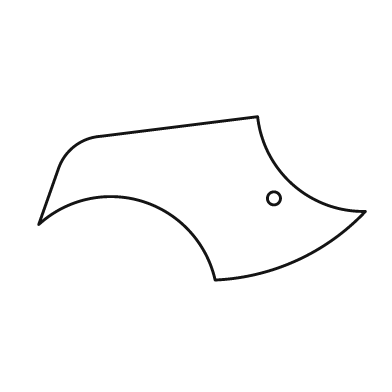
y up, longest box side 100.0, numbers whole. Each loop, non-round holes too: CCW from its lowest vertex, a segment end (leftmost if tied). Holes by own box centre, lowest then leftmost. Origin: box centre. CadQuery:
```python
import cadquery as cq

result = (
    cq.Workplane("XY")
    .moveTo(4.0, -25.0)
    .threePointArc((29.0, -19.0), (50.0, -4.0))
    .threePointArc((28.0, 4.0), (17.0, 25.0))
    .lineTo(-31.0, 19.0)
    .threePointArc((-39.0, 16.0), (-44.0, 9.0))
    .lineTo(-50.0, -8.0)
    .threePointArc((-18.0, -1.0), (4.0, -25.0))
    .close()
    .moveTo(22.0, 0.0)
    .circle(2.0)
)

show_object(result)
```